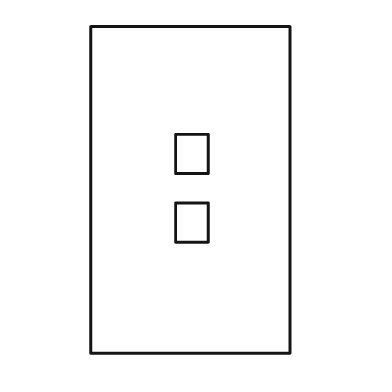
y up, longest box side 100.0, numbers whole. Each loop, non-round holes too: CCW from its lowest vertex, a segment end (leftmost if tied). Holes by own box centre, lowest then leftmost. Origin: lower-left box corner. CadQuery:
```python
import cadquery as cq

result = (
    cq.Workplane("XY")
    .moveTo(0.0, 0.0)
    .lineTo(61.0, 0.0)
    .lineTo(61.0, 100.0)
    .lineTo(0.0, 100.0)
    .close()
    .moveTo(26.0, 34.0)
    .lineTo(36.0, 34.0)
    .lineTo(36.0, 46.0)
    .lineTo(26.0, 46.0)
    .close()
    .moveTo(26.0, 55.0)
    .lineTo(36.0, 55.0)
    .lineTo(36.0, 67.0)
    .lineTo(26.0, 67.0)
    .close()
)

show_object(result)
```